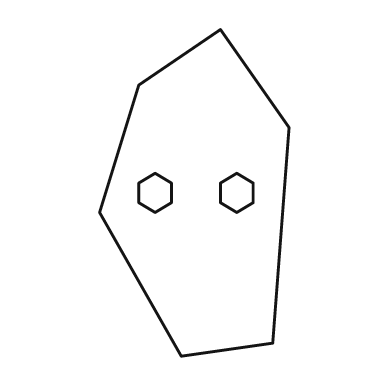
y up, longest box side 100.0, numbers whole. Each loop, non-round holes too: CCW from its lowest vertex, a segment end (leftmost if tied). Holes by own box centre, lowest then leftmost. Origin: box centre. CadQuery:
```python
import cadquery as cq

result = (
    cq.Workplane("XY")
    .moveTo(-4.0, -50.0)
    .lineTo(24.0, -46.0)
    .lineTo(29.0, 20.0)
    .lineTo(8.0, 50.0)
    .lineTo(-17.0, 33.0)
    .lineTo(-29.0, -6.0)
    .close()
    .moveTo(-12.0, -6.0)
    .lineTo(-7.0, -3.0)
    .lineTo(-7.0, 3.0)
    .lineTo(-12.0, 6.0)
    .lineTo(-17.0, 3.0)
    .lineTo(-17.0, -3.0)
    .close()
    .moveTo(13.0, -6.0)
    .lineTo(18.0, -3.0)
    .lineTo(18.0, 3.0)
    .lineTo(13.0, 6.0)
    .lineTo(8.0, 3.0)
    .lineTo(8.0, -3.0)
    .close()
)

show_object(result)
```